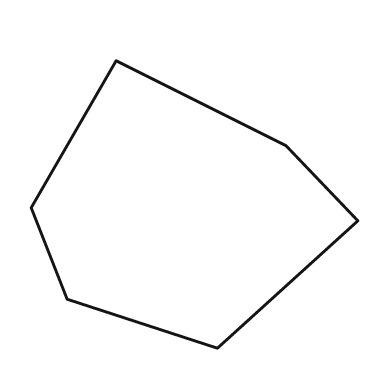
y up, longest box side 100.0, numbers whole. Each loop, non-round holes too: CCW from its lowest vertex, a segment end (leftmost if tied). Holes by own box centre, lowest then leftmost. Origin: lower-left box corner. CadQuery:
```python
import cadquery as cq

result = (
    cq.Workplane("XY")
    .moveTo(57.0, 0.0)
    .lineTo(100.0, 39.0)
    .lineTo(78.0, 62.0)
    .lineTo(26.0, 88.0)
    .lineTo(0.0, 43.0)
    .lineTo(11.0, 15.0)
    .close()
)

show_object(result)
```